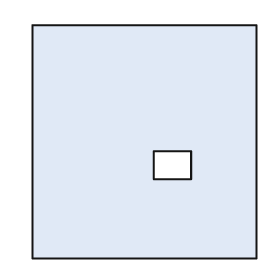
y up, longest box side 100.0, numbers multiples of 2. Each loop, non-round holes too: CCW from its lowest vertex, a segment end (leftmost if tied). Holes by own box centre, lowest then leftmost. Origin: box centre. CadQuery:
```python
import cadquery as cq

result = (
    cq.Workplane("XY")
    .moveTo(-48.0, -50.0)
    .lineTo(48.0, -50.0)
    .lineTo(48.0, 50.0)
    .lineTo(-48.0, 50.0)
    .close()
    .moveTo(4.0, -16.0)
    .lineTo(20.0, -16.0)
    .lineTo(20.0, -4.0)
    .lineTo(4.0, -4.0)
    .close()
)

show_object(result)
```